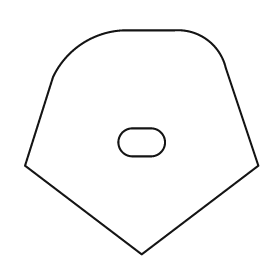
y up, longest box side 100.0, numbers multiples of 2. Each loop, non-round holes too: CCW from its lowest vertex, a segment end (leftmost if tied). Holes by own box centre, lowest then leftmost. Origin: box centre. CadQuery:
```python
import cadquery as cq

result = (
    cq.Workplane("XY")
    .moveTo(0.0, -48.0)
    .lineTo(50.0, -10.0)
    .lineTo(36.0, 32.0)
    .threePointArc((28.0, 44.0), (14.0, 48.0))
    .lineTo(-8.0, 48.0)
    .threePointArc((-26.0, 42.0), (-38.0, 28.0))
    .lineTo(-50.0, -10.0)
    .close()
    .moveTo(-4.0, -6.0)
    .lineTo(4.0, -6.0)
    .threePointArc((10.0, 0.0), (4.0, 6.0))
    .lineTo(-4.0, 6.0)
    .threePointArc((-10.0, 0.0), (-4.0, -6.0))
    .close()
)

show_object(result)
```